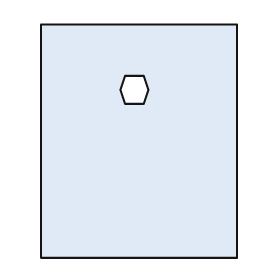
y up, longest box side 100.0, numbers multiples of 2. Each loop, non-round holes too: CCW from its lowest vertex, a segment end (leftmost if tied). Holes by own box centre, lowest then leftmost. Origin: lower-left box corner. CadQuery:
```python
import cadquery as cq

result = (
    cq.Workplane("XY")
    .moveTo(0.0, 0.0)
    .lineTo(84.0, 0.0)
    .lineTo(84.0, 100.0)
    .lineTo(0.0, 100.0)
    .close()
    .moveTo(36.0, 66.0)
    .lineTo(44.0, 66.0)
    .lineTo(46.0, 72.0)
    .lineTo(44.0, 78.0)
    .lineTo(36.0, 78.0)
    .lineTo(34.0, 72.0)
    .close()
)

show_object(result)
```